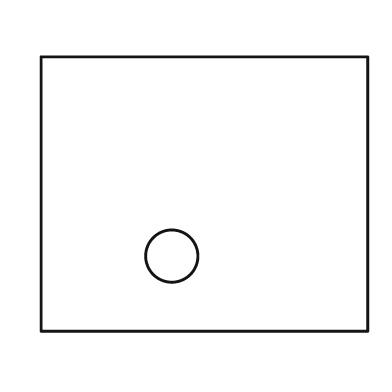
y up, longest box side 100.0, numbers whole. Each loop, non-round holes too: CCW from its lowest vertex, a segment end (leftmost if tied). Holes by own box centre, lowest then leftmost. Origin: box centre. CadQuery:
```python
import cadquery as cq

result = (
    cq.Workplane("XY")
    .moveTo(-50.0, -42.0)
    .lineTo(50.0, -42.0)
    .lineTo(50.0, 42.0)
    .lineTo(-50.0, 42.0)
    .close()
    .moveTo(-10.0, -19.0)
    .circle(8.0)
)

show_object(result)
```